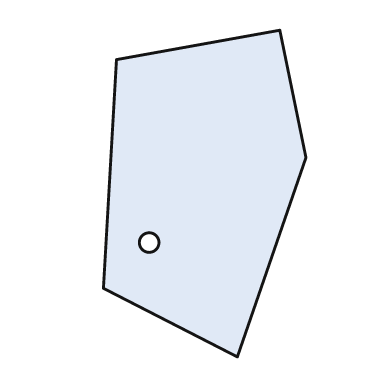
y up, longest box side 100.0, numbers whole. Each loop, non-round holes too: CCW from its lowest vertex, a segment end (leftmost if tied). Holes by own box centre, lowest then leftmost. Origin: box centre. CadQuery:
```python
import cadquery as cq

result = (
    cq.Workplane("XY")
    .moveTo(10.0, -50.0)
    .lineTo(31.0, 11.0)
    .lineTo(23.0, 50.0)
    .lineTo(-27.0, 41.0)
    .lineTo(-31.0, -29.0)
    .close()
    .moveTo(-17.0, -15.0)
    .circle(3.0)
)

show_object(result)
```